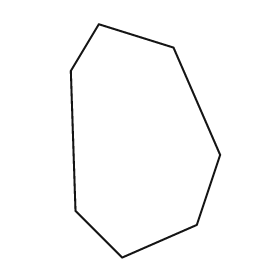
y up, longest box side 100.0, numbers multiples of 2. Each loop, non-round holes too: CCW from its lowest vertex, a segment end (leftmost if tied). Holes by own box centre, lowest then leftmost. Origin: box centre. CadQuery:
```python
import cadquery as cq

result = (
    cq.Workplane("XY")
    .moveTo(-10.0, -50.0)
    .lineTo(22.0, -36.0)
    .lineTo(32.0, -6.0)
    .lineTo(12.0, 40.0)
    .lineTo(-20.0, 50.0)
    .lineTo(-32.0, 30.0)
    .lineTo(-30.0, -30.0)
    .close()
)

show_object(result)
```